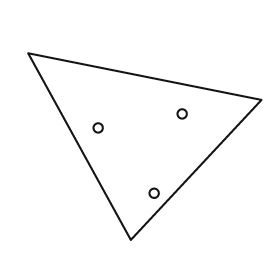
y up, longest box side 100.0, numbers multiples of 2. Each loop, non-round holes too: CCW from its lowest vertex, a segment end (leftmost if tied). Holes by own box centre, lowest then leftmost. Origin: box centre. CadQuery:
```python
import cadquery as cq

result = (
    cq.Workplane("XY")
    .moveTo(-6.0, -40.0)
    .lineTo(50.0, 20.0)
    .lineTo(-50.0, 40.0)
    .close()
    .moveTo(4.0, -20.0)
    .circle(2.0)
    .moveTo(-20.0, 8.0)
    .circle(2.0)
    .moveTo(16.0, 14.0)
    .circle(2.0)
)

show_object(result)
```